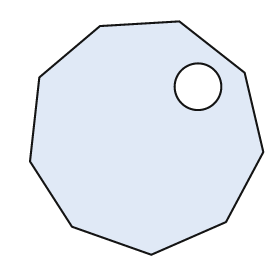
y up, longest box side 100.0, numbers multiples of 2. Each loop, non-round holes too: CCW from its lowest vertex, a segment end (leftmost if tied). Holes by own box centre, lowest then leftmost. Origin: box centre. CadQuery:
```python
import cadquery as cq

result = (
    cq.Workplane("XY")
    .moveTo(2.0, -50.0)
    .lineTo(34.0, -36.0)
    .lineTo(50.0, -6.0)
    .lineTo(42.0, 28.0)
    .lineTo(14.0, 50.0)
    .lineTo(-20.0, 48.0)
    .lineTo(-46.0, 26.0)
    .lineTo(-50.0, -10.0)
    .lineTo(-32.0, -38.0)
    .close()
    .moveTo(22.0, 22.0)
    .circle(10.0)
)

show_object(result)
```